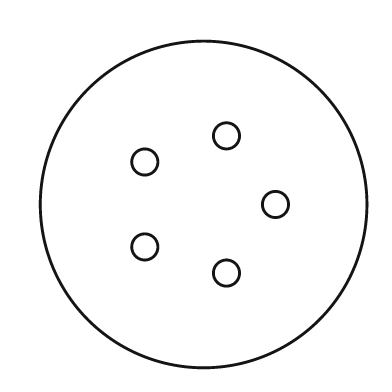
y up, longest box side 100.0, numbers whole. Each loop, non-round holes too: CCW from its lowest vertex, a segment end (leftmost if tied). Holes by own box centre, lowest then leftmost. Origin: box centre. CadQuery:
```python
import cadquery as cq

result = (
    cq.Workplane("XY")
    .moveTo(0.0, 0.0)
    .circle(50.0)
    .moveTo(7.0, -21.0)
    .circle(4.0)
    .moveTo(-18.0, -13.0)
    .circle(4.0)
    .moveTo(22.0, 0.0)
    .circle(4.0)
    .moveTo(-18.0, 13.0)
    .circle(4.0)
    .moveTo(7.0, 21.0)
    .circle(4.0)
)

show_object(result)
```